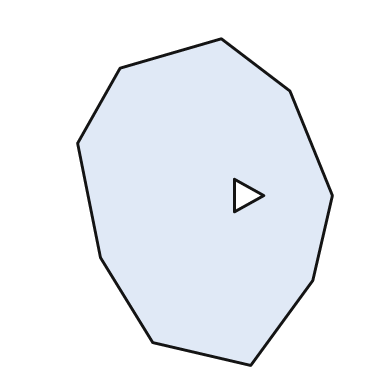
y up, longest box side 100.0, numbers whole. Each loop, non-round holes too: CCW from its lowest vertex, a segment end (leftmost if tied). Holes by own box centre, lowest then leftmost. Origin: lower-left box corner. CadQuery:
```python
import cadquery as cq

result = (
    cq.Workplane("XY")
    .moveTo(53.0, 0.0)
    .lineTo(72.0, 26.0)
    .lineTo(78.0, 52.0)
    .lineTo(65.0, 84.0)
    .lineTo(44.0, 100.0)
    .lineTo(13.0, 91.0)
    .lineTo(0.0, 68.0)
    .lineTo(7.0, 33.0)
    .lineTo(23.0, 7.0)
    .close()
    .moveTo(48.0, 47.0)
    .lineTo(57.0, 52.0)
    .lineTo(48.0, 57.0)
    .close()
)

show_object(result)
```